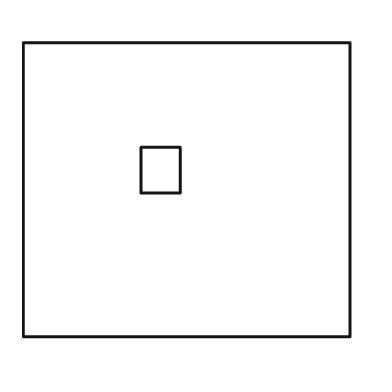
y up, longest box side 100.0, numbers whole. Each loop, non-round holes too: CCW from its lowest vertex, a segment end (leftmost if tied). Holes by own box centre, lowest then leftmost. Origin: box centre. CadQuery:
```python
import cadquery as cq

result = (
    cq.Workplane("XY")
    .moveTo(-50.0, -45.0)
    .lineTo(50.0, -45.0)
    .lineTo(50.0, 45.0)
    .lineTo(-50.0, 45.0)
    .close()
    .moveTo(-14.0, -1.0)
    .lineTo(-2.0, -1.0)
    .lineTo(-2.0, 13.0)
    .lineTo(-14.0, 13.0)
    .close()
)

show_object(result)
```